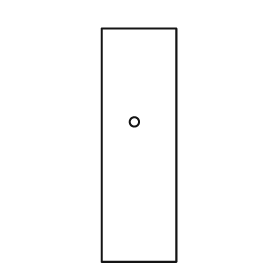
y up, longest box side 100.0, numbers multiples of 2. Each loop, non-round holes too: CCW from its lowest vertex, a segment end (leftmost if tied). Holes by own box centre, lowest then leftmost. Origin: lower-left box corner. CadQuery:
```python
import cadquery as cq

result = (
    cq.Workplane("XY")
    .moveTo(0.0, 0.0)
    .lineTo(32.0, 0.0)
    .lineTo(32.0, 100.0)
    .lineTo(0.0, 100.0)
    .close()
    .moveTo(14.0, 60.0)
    .circle(2.0)
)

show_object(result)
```